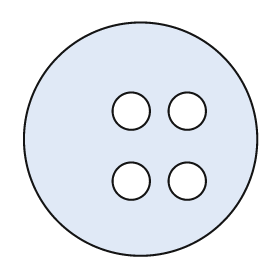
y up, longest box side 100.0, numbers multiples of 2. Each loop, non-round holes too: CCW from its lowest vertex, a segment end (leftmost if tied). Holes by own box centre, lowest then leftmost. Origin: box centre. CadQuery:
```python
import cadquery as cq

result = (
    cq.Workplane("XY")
    .moveTo(0.0, 0.0)
    .circle(50.0)
    .moveTo(-4.0, -18.0)
    .circle(8.0)
    .moveTo(20.0, -18.0)
    .circle(8.0)
    .moveTo(-4.0, 12.0)
    .circle(8.0)
    .moveTo(20.0, 12.0)
    .circle(8.0)
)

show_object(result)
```